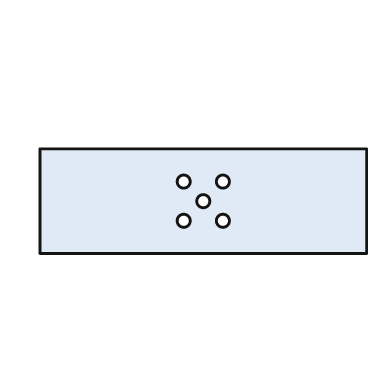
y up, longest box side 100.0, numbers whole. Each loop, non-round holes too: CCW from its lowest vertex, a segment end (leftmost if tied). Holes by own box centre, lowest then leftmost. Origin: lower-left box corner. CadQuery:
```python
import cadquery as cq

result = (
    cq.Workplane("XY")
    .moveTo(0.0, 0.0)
    .lineTo(100.0, 0.0)
    .lineTo(100.0, 32.0)
    .lineTo(0.0, 32.0)
    .close()
    .moveTo(44.0, 10.0)
    .circle(2.0)
    .moveTo(56.0, 10.0)
    .circle(2.0)
    .moveTo(50.0, 16.0)
    .circle(2.0)
    .moveTo(44.0, 22.0)
    .circle(2.0)
    .moveTo(56.0, 22.0)
    .circle(2.0)
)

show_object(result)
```